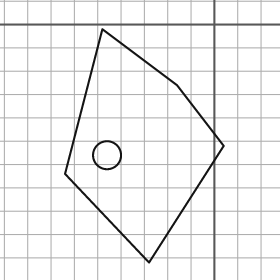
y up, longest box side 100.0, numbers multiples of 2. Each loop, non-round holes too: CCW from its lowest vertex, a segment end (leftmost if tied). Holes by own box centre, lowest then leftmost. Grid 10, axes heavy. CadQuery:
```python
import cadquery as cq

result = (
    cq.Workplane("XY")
    .moveTo(-28.0, -102.0)
    .lineTo(4.0, -52.0)
    .lineTo(-16.0, -26.0)
    .lineTo(-48.0, -2.0)
    .lineTo(-64.0, -64.0)
    .close()
    .moveTo(-46.0, -56.0)
    .circle(6.0)
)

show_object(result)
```